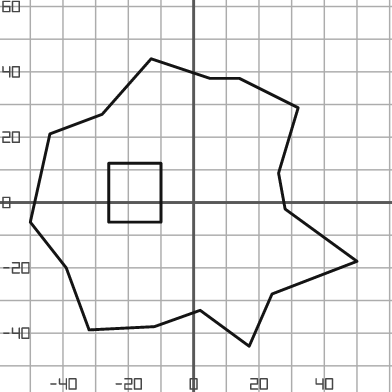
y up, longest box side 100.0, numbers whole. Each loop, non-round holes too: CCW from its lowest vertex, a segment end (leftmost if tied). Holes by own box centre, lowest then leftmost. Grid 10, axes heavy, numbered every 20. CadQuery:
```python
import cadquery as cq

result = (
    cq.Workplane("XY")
    .moveTo(17.0, -44.0)
    .lineTo(24.0, -28.0)
    .lineTo(50.0, -18.0)
    .lineTo(28.0, -2.0)
    .lineTo(26.0, 9.0)
    .lineTo(32.0, 29.0)
    .lineTo(14.0, 38.0)
    .lineTo(5.0, 38.0)
    .lineTo(-13.0, 44.0)
    .lineTo(-28.0, 27.0)
    .lineTo(-44.0, 21.0)
    .lineTo(-50.0, -6.0)
    .lineTo(-39.0, -20.0)
    .lineTo(-32.0, -39.0)
    .lineTo(-12.0, -38.0)
    .lineTo(2.0, -33.0)
    .close()
    .moveTo(-26.0, -6.0)
    .lineTo(-10.0, -6.0)
    .lineTo(-10.0, 12.0)
    .lineTo(-26.0, 12.0)
    .close()
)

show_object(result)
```